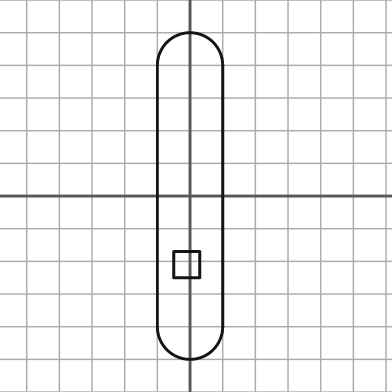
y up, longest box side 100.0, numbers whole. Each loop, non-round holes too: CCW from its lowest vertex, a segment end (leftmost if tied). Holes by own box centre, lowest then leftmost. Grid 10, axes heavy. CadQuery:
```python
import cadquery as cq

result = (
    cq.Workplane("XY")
    .moveTo(-10.0, -40.0)
    .threePointArc((0.0, -50.0), (10.0, -40.0))
    .lineTo(10.0, 40.0)
    .threePointArc((0.0, 50.0), (-10.0, 40.0))
    .close()
    .moveTo(-5.0, -25.0)
    .lineTo(3.0, -25.0)
    .lineTo(3.0, -17.0)
    .lineTo(-5.0, -17.0)
    .close()
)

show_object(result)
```